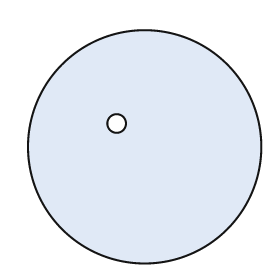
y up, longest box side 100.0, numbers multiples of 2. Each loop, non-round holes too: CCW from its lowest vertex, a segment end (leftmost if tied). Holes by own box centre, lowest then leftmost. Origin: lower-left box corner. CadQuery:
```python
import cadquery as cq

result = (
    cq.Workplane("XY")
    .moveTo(50.0, 50.0)
    .circle(50.0)
    .moveTo(38.0, 60.0)
    .circle(4.0)
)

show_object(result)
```